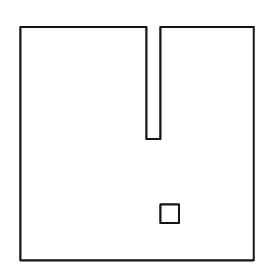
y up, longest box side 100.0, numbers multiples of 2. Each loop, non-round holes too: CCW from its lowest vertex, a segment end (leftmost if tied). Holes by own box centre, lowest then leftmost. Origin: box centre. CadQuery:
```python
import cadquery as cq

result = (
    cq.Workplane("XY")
    .moveTo(-50.0, -50.0)
    .lineTo(50.0, -50.0)
    .lineTo(50.0, 50.0)
    .lineTo(10.0, 50.0)
    .lineTo(10.0, 2.0)
    .lineTo(4.0, 2.0)
    .lineTo(4.0, 50.0)
    .lineTo(-50.0, 50.0)
    .close()
    .moveTo(10.0, -34.0)
    .lineTo(18.0, -34.0)
    .lineTo(18.0, -26.0)
    .lineTo(10.0, -26.0)
    .close()
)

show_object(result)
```